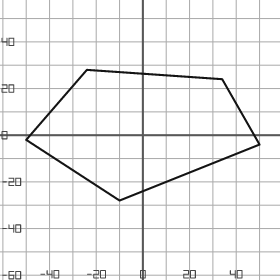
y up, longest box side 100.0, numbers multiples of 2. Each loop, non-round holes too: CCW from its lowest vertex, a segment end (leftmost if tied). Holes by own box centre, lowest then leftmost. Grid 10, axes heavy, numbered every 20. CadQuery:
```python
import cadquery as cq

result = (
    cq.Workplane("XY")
    .moveTo(-10.0, -28.0)
    .lineTo(50.0, -4.0)
    .lineTo(34.0, 24.0)
    .lineTo(-24.0, 28.0)
    .lineTo(-50.0, -2.0)
    .close()
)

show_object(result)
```